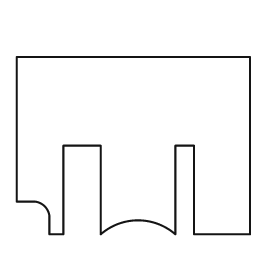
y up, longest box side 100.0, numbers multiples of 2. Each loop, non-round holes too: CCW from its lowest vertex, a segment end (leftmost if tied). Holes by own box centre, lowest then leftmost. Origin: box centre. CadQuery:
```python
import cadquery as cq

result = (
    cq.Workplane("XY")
    .moveTo(-36.0, -38.0)
    .lineTo(-30.0, -38.0)
    .lineTo(-30.0, 0.0)
    .lineTo(-14.0, 0.0)
    .lineTo(-14.0, -38.0)
    .threePointArc((2.0, -32.0), (18.0, -38.0))
    .lineTo(18.0, 0.0)
    .lineTo(26.0, 0.0)
    .lineTo(26.0, -38.0)
    .lineTo(50.0, -38.0)
    .lineTo(50.0, 38.0)
    .lineTo(-50.0, 38.0)
    .lineTo(-50.0, -24.0)
    .lineTo(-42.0, -24.0)
    .threePointArc((-38.0, -26.0), (-36.0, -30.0))
    .close()
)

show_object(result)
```